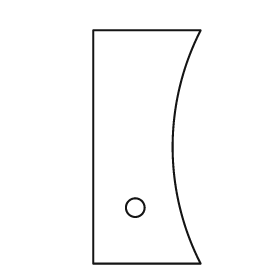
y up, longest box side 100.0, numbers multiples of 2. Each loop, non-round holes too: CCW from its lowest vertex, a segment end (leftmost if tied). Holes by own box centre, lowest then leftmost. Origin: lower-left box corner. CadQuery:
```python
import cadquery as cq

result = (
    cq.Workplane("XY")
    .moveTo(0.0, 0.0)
    .lineTo(46.0, 0.0)
    .threePointArc((34.0, 50.0), (46.0, 100.0))
    .lineTo(0.0, 100.0)
    .close()
    .moveTo(18.0, 24.0)
    .circle(4.0)
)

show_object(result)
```